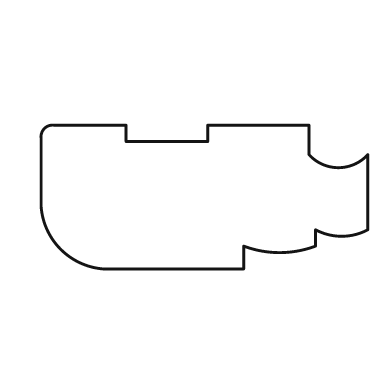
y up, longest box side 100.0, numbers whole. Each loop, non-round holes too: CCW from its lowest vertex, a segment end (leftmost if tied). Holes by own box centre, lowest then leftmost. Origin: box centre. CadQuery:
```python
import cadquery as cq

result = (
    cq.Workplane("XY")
    .moveTo(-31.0, -22.0)
    .lineTo(12.0, -22.0)
    .lineTo(12.0, -15.0)
    .threePointArc((23.0, -17.0), (34.0, -15.0))
    .lineTo(34.0, -10.0)
    .threePointArc((42.0, -12.0), (50.0, -10.0))
    .lineTo(50.0, 13.0)
    .threePointArc((41.0, 9.0), (32.0, 13.0))
    .lineTo(32.0, 22.0)
    .lineTo(1.0, 22.0)
    .lineTo(1.0, 17.0)
    .lineTo(-24.0, 17.0)
    .lineTo(-24.0, 22.0)
    .lineTo(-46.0, 22.0)
    .threePointArc((-49.0, 21.0), (-50.0, 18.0))
    .lineTo(-50.0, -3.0)
    .threePointArc((-44.0, -16.0), (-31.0, -22.0))
    .close()
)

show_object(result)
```